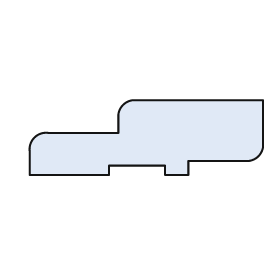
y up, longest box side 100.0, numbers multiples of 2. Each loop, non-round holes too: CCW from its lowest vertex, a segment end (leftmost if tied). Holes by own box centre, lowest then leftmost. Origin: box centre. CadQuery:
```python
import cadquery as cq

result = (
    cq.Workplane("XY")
    .moveTo(-50.0, -16.0)
    .lineTo(-16.0, -16.0)
    .lineTo(-16.0, -12.0)
    .lineTo(8.0, -12.0)
    .lineTo(8.0, -16.0)
    .lineTo(18.0, -16.0)
    .lineTo(18.0, -10.0)
    .lineTo(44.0, -10.0)
    .threePointArc((48.0, -8.0), (50.0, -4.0))
    .lineTo(50.0, 16.0)
    .lineTo(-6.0, 16.0)
    .threePointArc((-10.0, 14.0), (-12.0, 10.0))
    .lineTo(-12.0, 2.0)
    .lineTo(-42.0, 2.0)
    .threePointArc((-48.0, 0.0), (-50.0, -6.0))
    .close()
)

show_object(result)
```